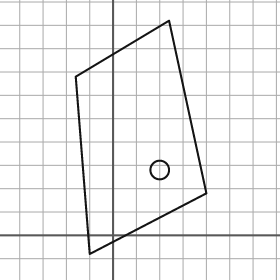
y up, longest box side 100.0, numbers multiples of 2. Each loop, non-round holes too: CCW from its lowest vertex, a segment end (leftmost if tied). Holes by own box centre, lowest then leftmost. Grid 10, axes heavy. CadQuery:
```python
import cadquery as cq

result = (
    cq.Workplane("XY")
    .moveTo(-10.0, -8.0)
    .lineTo(40.0, 18.0)
    .lineTo(24.0, 92.0)
    .lineTo(-16.0, 68.0)
    .close()
    .moveTo(20.0, 28.0)
    .circle(4.0)
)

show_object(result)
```